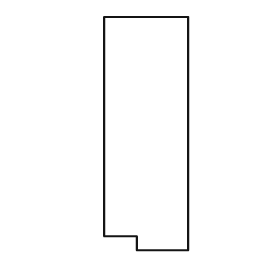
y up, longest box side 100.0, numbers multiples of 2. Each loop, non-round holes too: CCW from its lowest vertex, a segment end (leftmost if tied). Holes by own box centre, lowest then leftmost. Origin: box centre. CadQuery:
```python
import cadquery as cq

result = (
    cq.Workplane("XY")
    .moveTo(-4.0, -50.0)
    .lineTo(18.0, -50.0)
    .lineTo(18.0, 50.0)
    .lineTo(-18.0, 50.0)
    .lineTo(-18.0, -44.0)
    .lineTo(-4.0, -44.0)
    .close()
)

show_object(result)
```